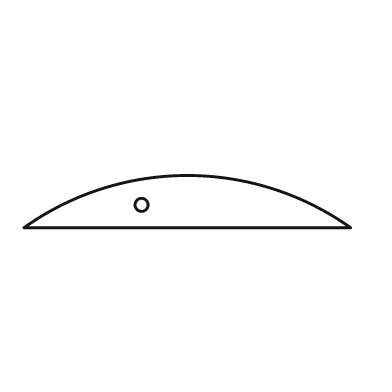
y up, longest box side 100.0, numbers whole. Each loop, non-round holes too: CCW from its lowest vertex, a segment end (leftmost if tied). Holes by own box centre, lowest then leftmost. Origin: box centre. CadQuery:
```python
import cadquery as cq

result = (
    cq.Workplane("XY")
    .moveTo(-50.0, -8.0)
    .lineTo(50.0, -8.0)
    .threePointArc((0.0, 8.0), (-50.0, -8.0))
    .close()
    .moveTo(-14.0, -1.0)
    .circle(2.0)
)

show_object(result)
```